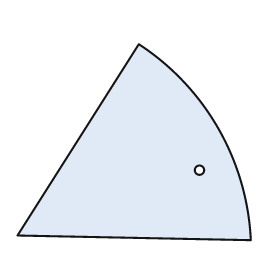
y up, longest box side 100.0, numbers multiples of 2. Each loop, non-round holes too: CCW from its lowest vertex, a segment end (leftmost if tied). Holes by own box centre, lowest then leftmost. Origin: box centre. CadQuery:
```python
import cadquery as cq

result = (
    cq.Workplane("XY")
    .moveTo(50.0, -42.0)
    .threePointArc((36.0, 6.0), (2.0, 42.0))
    .lineTo(-50.0, -40.0)
    .close()
    .moveTo(28.0, -12.0)
    .circle(2.0)
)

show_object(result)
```